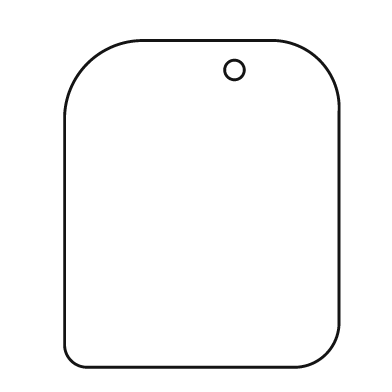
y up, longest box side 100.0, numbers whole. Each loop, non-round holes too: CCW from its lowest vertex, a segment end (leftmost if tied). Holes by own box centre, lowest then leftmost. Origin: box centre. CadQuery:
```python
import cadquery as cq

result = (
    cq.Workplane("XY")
    .moveTo(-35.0, -50.0)
    .lineTo(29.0, -50.0)
    .threePointArc((38.0, -46.0), (42.0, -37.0))
    .lineTo(42.0, 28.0)
    .threePointArc((36.0, 44.0), (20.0, 50.0))
    .lineTo(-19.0, 50.0)
    .threePointArc((-35.0, 43.0), (-42.0, 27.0))
    .lineTo(-42.0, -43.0)
    .threePointArc((-40.0, -48.0), (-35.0, -50.0))
    .close()
    .moveTo(10.0, 41.0)
    .circle(3.0)
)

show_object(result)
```